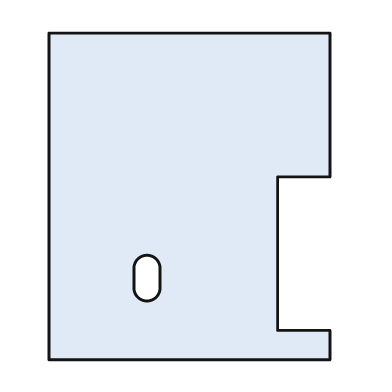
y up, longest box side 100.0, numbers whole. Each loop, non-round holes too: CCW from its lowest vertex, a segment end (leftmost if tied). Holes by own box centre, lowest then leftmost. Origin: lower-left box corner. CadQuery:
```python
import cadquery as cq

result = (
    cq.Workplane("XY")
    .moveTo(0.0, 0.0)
    .lineTo(86.0, 0.0)
    .lineTo(86.0, 9.0)
    .lineTo(70.0, 9.0)
    .lineTo(70.0, 56.0)
    .lineTo(86.0, 56.0)
    .lineTo(86.0, 100.0)
    .lineTo(0.0, 100.0)
    .close()
    .moveTo(26.0, 22.0)
    .threePointArc((30.0, 18.0), (34.0, 22.0))
    .lineTo(34.0, 28.0)
    .threePointArc((30.0, 32.0), (26.0, 28.0))
    .close()
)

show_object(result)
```